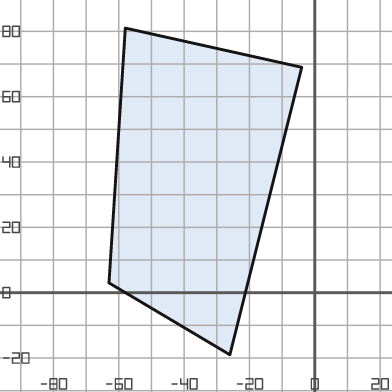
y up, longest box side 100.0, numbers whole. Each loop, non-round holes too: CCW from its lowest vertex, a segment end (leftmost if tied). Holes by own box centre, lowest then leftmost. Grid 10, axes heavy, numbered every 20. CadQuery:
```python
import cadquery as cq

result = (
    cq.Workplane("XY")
    .moveTo(-26.0, -19.0)
    .lineTo(-4.0, 69.0)
    .lineTo(-58.0, 81.0)
    .lineTo(-63.0, 3.0)
    .close()
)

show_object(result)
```